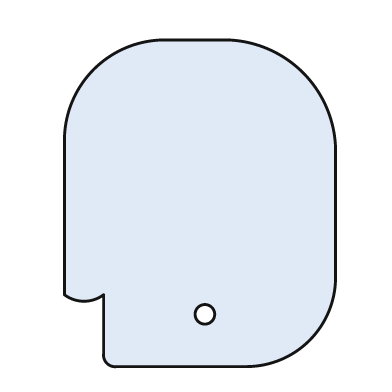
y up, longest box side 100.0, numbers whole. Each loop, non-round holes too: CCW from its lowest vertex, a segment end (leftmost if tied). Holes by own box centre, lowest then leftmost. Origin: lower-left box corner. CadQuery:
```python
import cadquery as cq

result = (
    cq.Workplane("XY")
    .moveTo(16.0, 0.0)
    .lineTo(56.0, 0.0)
    .threePointArc((75.0, 8.0), (83.0, 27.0))
    .lineTo(83.0, 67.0)
    .threePointArc((73.0, 90.0), (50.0, 100.0))
    .lineTo(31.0, 100.0)
    .threePointArc((9.0, 91.0), (0.0, 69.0))
    .lineTo(0.0, 22.0)
    .threePointArc((6.0, 20.0), (12.0, 22.0))
    .lineTo(12.0, 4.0)
    .threePointArc((13.0, 1.0), (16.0, 0.0))
    .close()
    .moveTo(43.0, 16.0)
    .circle(3.0)
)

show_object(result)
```